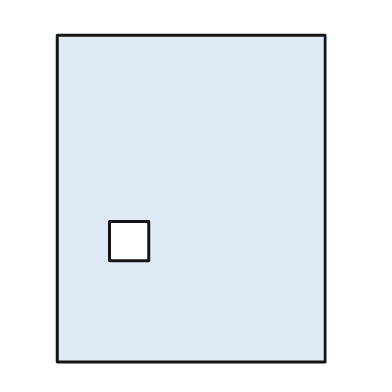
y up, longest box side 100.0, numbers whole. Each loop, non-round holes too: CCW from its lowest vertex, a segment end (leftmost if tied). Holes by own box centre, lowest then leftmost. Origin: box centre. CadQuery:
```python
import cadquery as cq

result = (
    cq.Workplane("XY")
    .moveTo(-41.0, -50.0)
    .lineTo(41.0, -50.0)
    .lineTo(41.0, 50.0)
    .lineTo(-41.0, 50.0)
    .close()
    .moveTo(-25.0, -19.0)
    .lineTo(-13.0, -19.0)
    .lineTo(-13.0, -7.0)
    .lineTo(-25.0, -7.0)
    .close()
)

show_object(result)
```